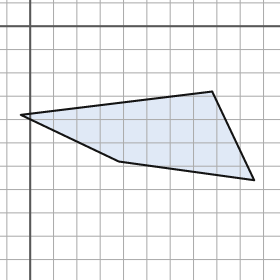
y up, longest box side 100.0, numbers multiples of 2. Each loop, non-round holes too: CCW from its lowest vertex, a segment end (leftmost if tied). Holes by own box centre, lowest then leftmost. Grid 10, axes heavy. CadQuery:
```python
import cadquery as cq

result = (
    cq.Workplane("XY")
    .moveTo(96.0, -66.0)
    .lineTo(78.0, -28.0)
    .lineTo(-4.0, -38.0)
    .lineTo(38.0, -58.0)
    .close()
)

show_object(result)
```